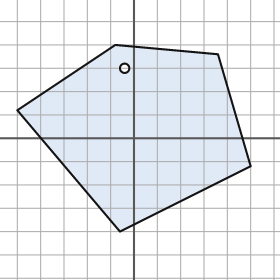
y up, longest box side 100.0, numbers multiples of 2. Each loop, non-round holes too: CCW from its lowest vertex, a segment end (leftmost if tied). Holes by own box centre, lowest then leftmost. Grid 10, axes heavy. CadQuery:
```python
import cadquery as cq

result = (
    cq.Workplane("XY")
    .moveTo(-6.0, -40.0)
    .lineTo(50.0, -12.0)
    .lineTo(36.0, 36.0)
    .lineTo(-8.0, 40.0)
    .lineTo(-50.0, 12.0)
    .close()
    .moveTo(-4.0, 30.0)
    .circle(2.0)
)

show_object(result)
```